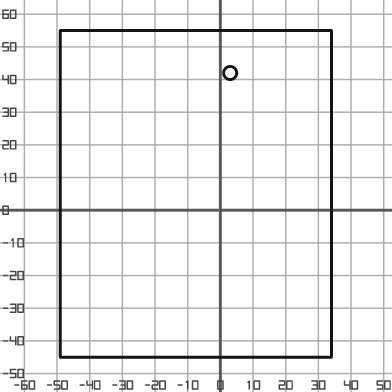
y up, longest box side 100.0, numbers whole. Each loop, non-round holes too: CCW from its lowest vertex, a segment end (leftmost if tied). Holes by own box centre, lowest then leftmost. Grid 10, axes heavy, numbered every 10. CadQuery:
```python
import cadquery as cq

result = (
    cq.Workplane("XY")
    .moveTo(-49.0, -45.0)
    .lineTo(34.0, -45.0)
    .lineTo(34.0, 55.0)
    .lineTo(-49.0, 55.0)
    .close()
    .moveTo(3.0, 42.0)
    .circle(2.0)
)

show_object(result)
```